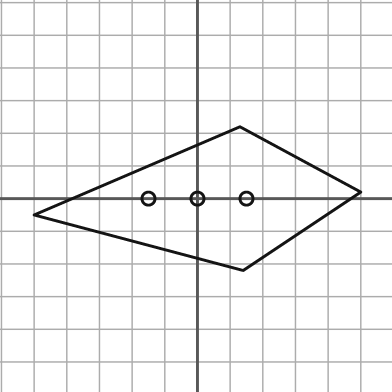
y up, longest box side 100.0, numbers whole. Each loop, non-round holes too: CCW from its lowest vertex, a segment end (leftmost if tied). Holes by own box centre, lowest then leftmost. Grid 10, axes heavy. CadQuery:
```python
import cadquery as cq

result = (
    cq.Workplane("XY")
    .moveTo(14.0, -22.0)
    .lineTo(50.0, 2.0)
    .lineTo(13.0, 22.0)
    .lineTo(-50.0, -5.0)
    .close()
    .moveTo(-15.0, 0.0)
    .circle(2.0)
    .moveTo(0.0, 0.0)
    .circle(2.0)
    .moveTo(15.0, 0.0)
    .circle(2.0)
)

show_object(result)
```